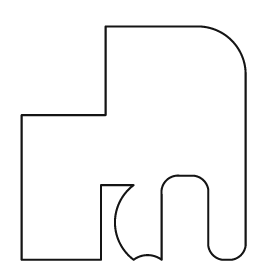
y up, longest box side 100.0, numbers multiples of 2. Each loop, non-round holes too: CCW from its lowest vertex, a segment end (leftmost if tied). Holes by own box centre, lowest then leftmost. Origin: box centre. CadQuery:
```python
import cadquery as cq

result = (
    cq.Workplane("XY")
    .moveTo(-48.0, -50.0)
    .lineTo(-14.0, -50.0)
    .lineTo(-14.0, -18.0)
    .lineTo(0.0, -18.0)
    .threePointArc((-8.0, -34.0), (0.0, -50.0))
    .threePointArc((6.0, -48.0), (12.0, -50.0))
    .lineTo(12.0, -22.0)
    .threePointArc((14.0, -16.0), (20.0, -14.0))
    .lineTo(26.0, -14.0)
    .threePointArc((30.0, -16.0), (32.0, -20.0))
    .lineTo(32.0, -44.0)
    .threePointArc((34.0, -48.0), (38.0, -50.0))
    .lineTo(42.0, -50.0)
    .threePointArc((46.0, -48.0), (48.0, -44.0))
    .lineTo(48.0, 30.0)
    .threePointArc((42.0, 44.0), (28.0, 50.0))
    .lineTo(-12.0, 50.0)
    .lineTo(-12.0, 12.0)
    .lineTo(-48.0, 12.0)
    .close()
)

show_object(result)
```